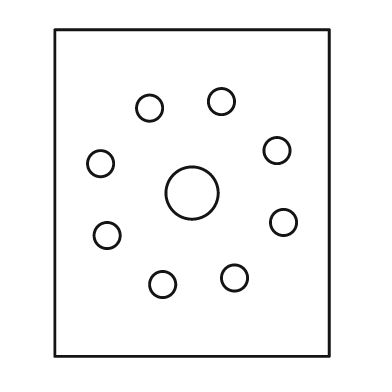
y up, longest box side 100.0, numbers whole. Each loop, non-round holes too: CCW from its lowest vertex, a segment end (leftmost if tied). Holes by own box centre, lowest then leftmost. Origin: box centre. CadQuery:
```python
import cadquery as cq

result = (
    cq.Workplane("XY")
    .moveTo(-42.0, -50.0)
    .lineTo(42.0, -50.0)
    .lineTo(42.0, 50.0)
    .lineTo(-42.0, 50.0)
    .close()
    .moveTo(-9.0, -28.0)
    .circle(4.0)
    .moveTo(13.0, -26.0)
    .circle(4.0)
    .moveTo(-26.0, -13.0)
    .circle(4.0)
    .moveTo(28.0, -9.0)
    .circle(4.0)
    .moveTo(0.0, 0.0)
    .circle(8.0)
    .moveTo(-28.0, 9.0)
    .circle(4.0)
    .moveTo(26.0, 13.0)
    .circle(4.0)
    .moveTo(-13.0, 26.0)
    .circle(4.0)
    .moveTo(9.0, 28.0)
    .circle(4.0)
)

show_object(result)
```